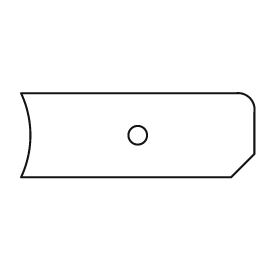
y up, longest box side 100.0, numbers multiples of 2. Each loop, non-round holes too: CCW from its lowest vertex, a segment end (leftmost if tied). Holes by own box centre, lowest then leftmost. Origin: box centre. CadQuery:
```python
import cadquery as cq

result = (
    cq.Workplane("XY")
    .moveTo(-50.0, -18.0)
    .lineTo(40.0, -18.0)
    .lineTo(50.0, -8.0)
    .lineTo(50.0, 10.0)
    .threePointArc((48.0, 16.0), (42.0, 18.0))
    .lineTo(-50.0, 18.0)
    .threePointArc((-46.0, 0.0), (-50.0, -18.0))
    .close()
    .moveTo(0.0, 0.0)
    .circle(4.0)
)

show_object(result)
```